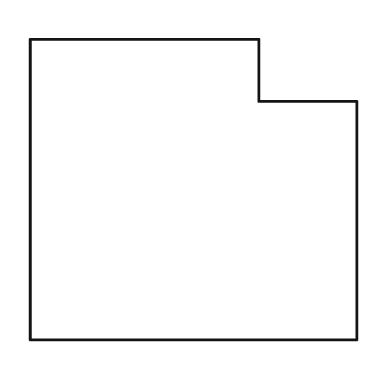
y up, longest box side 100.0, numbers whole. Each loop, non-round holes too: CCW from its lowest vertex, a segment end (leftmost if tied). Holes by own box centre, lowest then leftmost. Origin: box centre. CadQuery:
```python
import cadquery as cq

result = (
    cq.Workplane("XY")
    .moveTo(-50.0, -46.0)
    .lineTo(50.0, -46.0)
    .lineTo(50.0, 27.0)
    .lineTo(20.0, 27.0)
    .lineTo(20.0, 46.0)
    .lineTo(-50.0, 46.0)
    .close()
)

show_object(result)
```